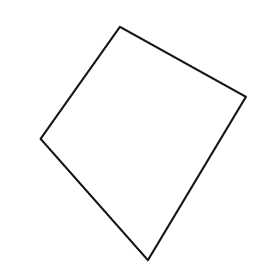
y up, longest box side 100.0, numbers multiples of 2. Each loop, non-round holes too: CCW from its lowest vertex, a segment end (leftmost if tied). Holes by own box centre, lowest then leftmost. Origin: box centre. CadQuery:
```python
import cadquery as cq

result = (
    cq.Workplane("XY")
    .moveTo(2.0, -50.0)
    .lineTo(44.0, 20.0)
    .lineTo(-10.0, 50.0)
    .lineTo(-44.0, 2.0)
    .close()
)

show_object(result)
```